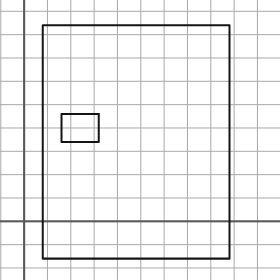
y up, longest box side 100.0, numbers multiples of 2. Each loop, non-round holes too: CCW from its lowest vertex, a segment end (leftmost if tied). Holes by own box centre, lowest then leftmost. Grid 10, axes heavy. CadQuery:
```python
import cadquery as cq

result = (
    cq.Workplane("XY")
    .moveTo(8.0, -16.0)
    .lineTo(88.0, -16.0)
    .lineTo(88.0, 84.0)
    .lineTo(8.0, 84.0)
    .close()
    .moveTo(16.0, 34.0)
    .lineTo(32.0, 34.0)
    .lineTo(32.0, 46.0)
    .lineTo(16.0, 46.0)
    .close()
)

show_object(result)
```